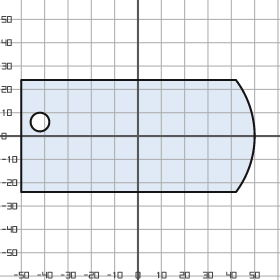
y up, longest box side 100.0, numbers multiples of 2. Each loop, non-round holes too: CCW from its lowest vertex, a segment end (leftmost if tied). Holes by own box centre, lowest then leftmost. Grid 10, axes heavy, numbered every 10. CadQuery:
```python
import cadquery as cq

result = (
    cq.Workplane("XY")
    .moveTo(-50.0, -24.0)
    .lineTo(42.0, -24.0)
    .threePointArc((50.0, 0.0), (42.0, 24.0))
    .lineTo(-50.0, 24.0)
    .close()
    .moveTo(-42.0, 6.0)
    .circle(4.0)
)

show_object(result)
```